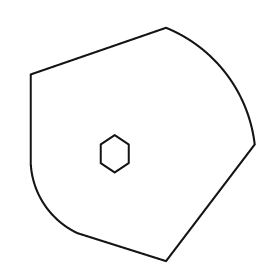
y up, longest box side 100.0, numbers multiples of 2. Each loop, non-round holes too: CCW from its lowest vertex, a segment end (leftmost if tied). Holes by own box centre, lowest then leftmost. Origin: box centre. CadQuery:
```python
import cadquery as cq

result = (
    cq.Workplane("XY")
    .moveTo(10.0, -50.0)
    .lineTo(48.0, 0.0)
    .threePointArc((36.0, 30.0), (10.0, 50.0))
    .lineTo(-48.0, 30.0)
    .lineTo(-48.0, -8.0)
    .threePointArc((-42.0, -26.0), (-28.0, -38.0))
    .close()
    .moveTo(-12.0, -12.0)
    .lineTo(-6.0, -8.0)
    .lineTo(-6.0, 0.0)
    .lineTo(-12.0, 4.0)
    .lineTo(-18.0, 0.0)
    .lineTo(-18.0, -8.0)
    .close()
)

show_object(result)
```